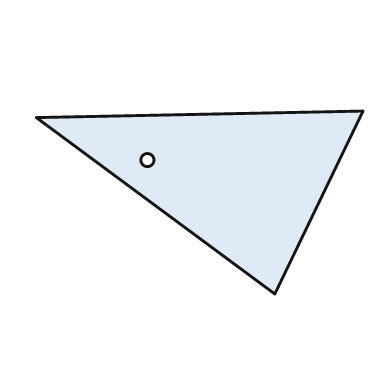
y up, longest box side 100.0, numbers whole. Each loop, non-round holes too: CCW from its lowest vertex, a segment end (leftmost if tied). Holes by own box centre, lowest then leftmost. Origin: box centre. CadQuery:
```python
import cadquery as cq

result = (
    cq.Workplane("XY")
    .moveTo(23.0, -28.0)
    .lineTo(50.0, 28.0)
    .lineTo(-50.0, 26.0)
    .close()
    .moveTo(-16.0, 13.0)
    .circle(2.0)
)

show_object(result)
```